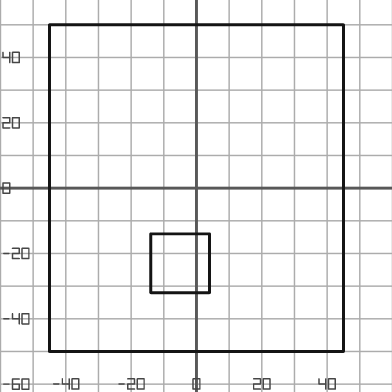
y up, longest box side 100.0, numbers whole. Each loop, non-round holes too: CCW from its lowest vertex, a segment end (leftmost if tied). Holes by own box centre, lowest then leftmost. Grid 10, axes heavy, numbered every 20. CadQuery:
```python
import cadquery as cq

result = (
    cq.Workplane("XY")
    .moveTo(-45.0, -50.0)
    .lineTo(45.0, -50.0)
    .lineTo(45.0, 50.0)
    .lineTo(-45.0, 50.0)
    .close()
    .moveTo(-14.0, -32.0)
    .lineTo(4.0, -32.0)
    .lineTo(4.0, -14.0)
    .lineTo(-14.0, -14.0)
    .close()
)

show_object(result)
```